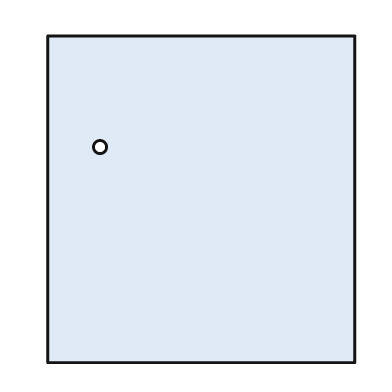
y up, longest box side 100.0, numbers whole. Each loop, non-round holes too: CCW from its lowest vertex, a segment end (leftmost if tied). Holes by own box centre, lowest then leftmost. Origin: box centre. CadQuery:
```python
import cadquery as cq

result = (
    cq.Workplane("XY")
    .moveTo(-47.0, -50.0)
    .lineTo(47.0, -50.0)
    .lineTo(47.0, 50.0)
    .lineTo(-47.0, 50.0)
    .close()
    .moveTo(-31.0, 16.0)
    .circle(2.0)
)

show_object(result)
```